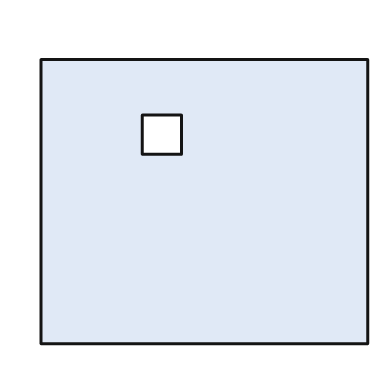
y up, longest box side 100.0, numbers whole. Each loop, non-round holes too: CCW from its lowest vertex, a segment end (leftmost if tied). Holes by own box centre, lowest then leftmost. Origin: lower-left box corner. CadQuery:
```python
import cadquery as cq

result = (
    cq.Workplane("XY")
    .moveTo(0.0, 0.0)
    .lineTo(100.0, 0.0)
    .lineTo(100.0, 87.0)
    .lineTo(0.0, 87.0)
    .close()
    .moveTo(31.0, 58.0)
    .lineTo(43.0, 58.0)
    .lineTo(43.0, 70.0)
    .lineTo(31.0, 70.0)
    .close()
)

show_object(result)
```